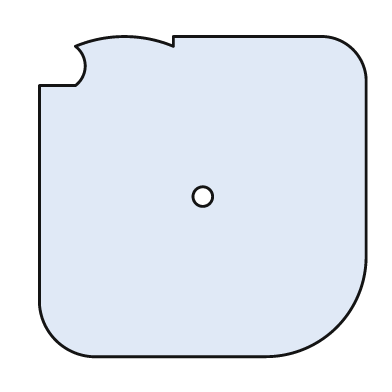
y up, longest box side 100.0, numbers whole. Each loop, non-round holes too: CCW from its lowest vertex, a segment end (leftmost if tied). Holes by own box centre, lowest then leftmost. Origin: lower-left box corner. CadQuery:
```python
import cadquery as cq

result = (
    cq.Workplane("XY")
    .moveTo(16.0, 0.0)
    .lineTo(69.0, 0.0)
    .threePointArc((91.0, 9.0), (100.0, 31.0))
    .lineTo(100.0, 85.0)
    .threePointArc((96.0, 94.0), (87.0, 98.0))
    .lineTo(41.0, 98.0)
    .lineTo(41.0, 95.0)
    .threePointArc((26.0, 98.0), (11.0, 95.0))
    .threePointArc((14.0, 89.0), (11.0, 83.0))
    .lineTo(0.0, 83.0)
    .lineTo(0.0, 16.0)
    .threePointArc((5.0, 5.0), (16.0, 0.0))
    .close()
    .moveTo(50.0, 49.0)
    .circle(3.0)
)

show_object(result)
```